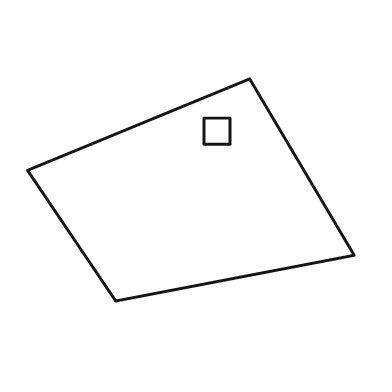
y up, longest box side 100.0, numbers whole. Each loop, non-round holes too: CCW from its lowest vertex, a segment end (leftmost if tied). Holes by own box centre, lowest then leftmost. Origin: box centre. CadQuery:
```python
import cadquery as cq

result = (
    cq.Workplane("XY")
    .moveTo(-23.0, -34.0)
    .lineTo(50.0, -20.0)
    .lineTo(18.0, 34.0)
    .lineTo(-50.0, 6.0)
    .close()
    .moveTo(4.0, 14.0)
    .lineTo(12.0, 14.0)
    .lineTo(12.0, 22.0)
    .lineTo(4.0, 22.0)
    .close()
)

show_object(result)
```